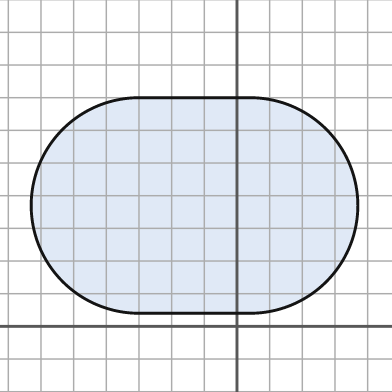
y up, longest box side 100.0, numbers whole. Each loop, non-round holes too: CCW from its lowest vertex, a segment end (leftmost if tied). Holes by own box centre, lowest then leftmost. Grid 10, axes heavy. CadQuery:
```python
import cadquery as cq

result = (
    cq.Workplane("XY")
    .moveTo(-30.0, 4.0)
    .lineTo(4.0, 4.0)
    .threePointArc((37.0, 37.0), (4.0, 70.0))
    .lineTo(-30.0, 70.0)
    .threePointArc((-63.0, 37.0), (-30.0, 4.0))
    .close()
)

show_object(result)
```